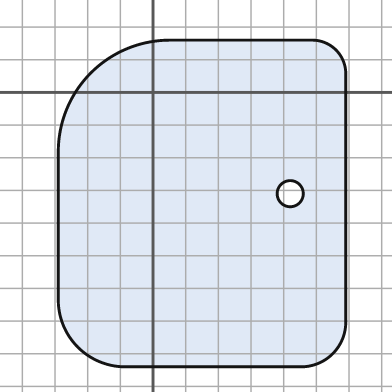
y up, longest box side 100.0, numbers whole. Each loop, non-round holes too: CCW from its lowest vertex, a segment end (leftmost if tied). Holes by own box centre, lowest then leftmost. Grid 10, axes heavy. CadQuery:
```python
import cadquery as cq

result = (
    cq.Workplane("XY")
    .moveTo(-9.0, -84.0)
    .lineTo(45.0, -84.0)
    .threePointArc((55.0, -80.0), (59.0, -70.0))
    .lineTo(59.0, 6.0)
    .threePointArc((56.0, 13.0), (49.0, 16.0))
    .lineTo(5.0, 16.0)
    .threePointArc((-19.0, 6.0), (-29.0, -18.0))
    .lineTo(-29.0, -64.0)
    .threePointArc((-23.0, -78.0), (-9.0, -84.0))
    .close()
    .moveTo(42.0, -31.0)
    .circle(4.0)
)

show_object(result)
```